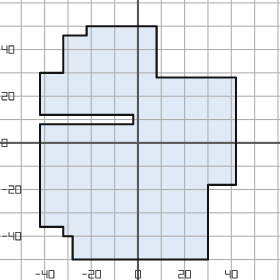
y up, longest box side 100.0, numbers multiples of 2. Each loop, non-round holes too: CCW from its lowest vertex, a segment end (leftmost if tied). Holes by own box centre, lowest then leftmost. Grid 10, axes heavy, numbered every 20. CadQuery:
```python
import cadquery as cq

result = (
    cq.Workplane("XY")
    .moveTo(-28.0, -50.0)
    .lineTo(30.0, -50.0)
    .lineTo(30.0, -18.0)
    .lineTo(42.0, -18.0)
    .lineTo(42.0, 28.0)
    .lineTo(8.0, 28.0)
    .lineTo(8.0, 50.0)
    .lineTo(-22.0, 50.0)
    .lineTo(-22.0, 46.0)
    .lineTo(-32.0, 46.0)
    .lineTo(-32.0, 30.0)
    .lineTo(-42.0, 30.0)
    .lineTo(-42.0, 12.0)
    .lineTo(-2.0, 12.0)
    .lineTo(-2.0, 8.0)
    .lineTo(-42.0, 8.0)
    .lineTo(-42.0, -36.0)
    .lineTo(-32.0, -36.0)
    .lineTo(-32.0, -40.0)
    .lineTo(-28.0, -40.0)
    .close()
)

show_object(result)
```